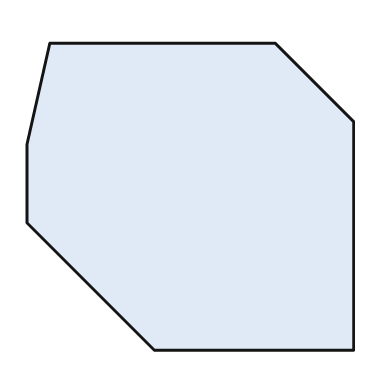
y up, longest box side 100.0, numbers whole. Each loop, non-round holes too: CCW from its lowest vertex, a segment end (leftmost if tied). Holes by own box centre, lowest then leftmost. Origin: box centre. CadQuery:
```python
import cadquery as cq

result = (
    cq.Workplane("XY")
    .moveTo(-11.0, -47.0)
    .lineTo(50.0, -47.0)
    .lineTo(50.0, 23.0)
    .lineTo(26.0, 47.0)
    .lineTo(-43.0, 47.0)
    .lineTo(-50.0, 16.0)
    .lineTo(-50.0, -8.0)
    .close()
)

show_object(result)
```